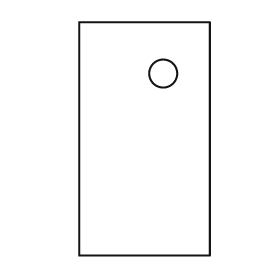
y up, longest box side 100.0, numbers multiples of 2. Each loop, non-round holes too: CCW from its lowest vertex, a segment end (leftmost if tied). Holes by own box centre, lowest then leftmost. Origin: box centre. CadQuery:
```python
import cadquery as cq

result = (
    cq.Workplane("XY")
    .moveTo(-28.0, -50.0)
    .lineTo(28.0, -50.0)
    .lineTo(28.0, 50.0)
    .lineTo(-28.0, 50.0)
    .close()
    .moveTo(8.0, 28.0)
    .circle(6.0)
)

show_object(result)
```